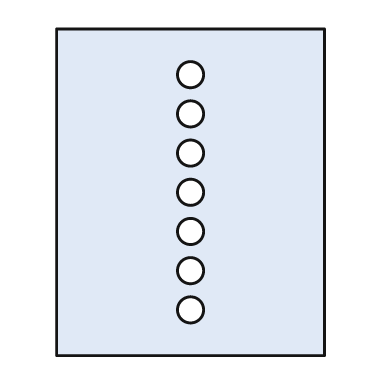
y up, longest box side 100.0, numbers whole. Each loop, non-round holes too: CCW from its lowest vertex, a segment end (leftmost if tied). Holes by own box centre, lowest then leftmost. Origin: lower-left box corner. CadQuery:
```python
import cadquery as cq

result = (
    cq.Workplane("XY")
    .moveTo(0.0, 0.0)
    .lineTo(82.0, 0.0)
    .lineTo(82.0, 100.0)
    .lineTo(0.0, 100.0)
    .close()
    .moveTo(41.0, 14.0)
    .circle(4.0)
    .moveTo(41.0, 26.0)
    .circle(4.0)
    .moveTo(41.0, 38.0)
    .circle(4.0)
    .moveTo(41.0, 50.0)
    .circle(4.0)
    .moveTo(41.0, 62.0)
    .circle(4.0)
    .moveTo(41.0, 74.0)
    .circle(4.0)
    .moveTo(41.0, 86.0)
    .circle(4.0)
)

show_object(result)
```